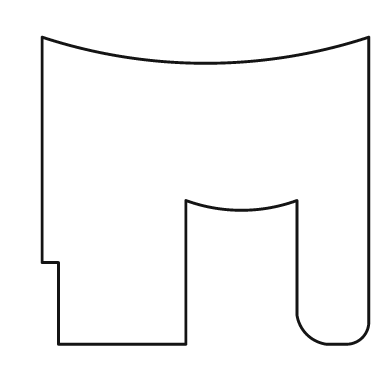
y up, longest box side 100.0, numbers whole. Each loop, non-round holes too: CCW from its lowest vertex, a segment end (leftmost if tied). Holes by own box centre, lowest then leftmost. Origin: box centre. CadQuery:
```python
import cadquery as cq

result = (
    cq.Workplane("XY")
    .moveTo(-45.0, -47.0)
    .lineTo(-6.0, -47.0)
    .lineTo(-6.0, -3.0)
    .threePointArc((11.0, -6.0), (28.0, -3.0))
    .lineTo(28.0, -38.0)
    .threePointArc((31.0, -44.0), (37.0, -47.0))
    .lineTo(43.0, -47.0)
    .threePointArc((48.0, -45.0), (50.0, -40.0))
    .lineTo(50.0, 47.0)
    .threePointArc((0.0, 39.0), (-50.0, 47.0))
    .lineTo(-50.0, -22.0)
    .lineTo(-45.0, -22.0)
    .close()
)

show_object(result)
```